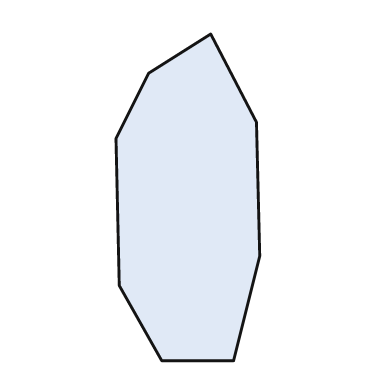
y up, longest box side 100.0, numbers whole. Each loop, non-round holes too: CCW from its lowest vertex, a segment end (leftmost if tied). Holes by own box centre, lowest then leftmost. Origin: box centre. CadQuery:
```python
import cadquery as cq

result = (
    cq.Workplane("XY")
    .moveTo(-8.0, -50.0)
    .lineTo(14.0, -50.0)
    .lineTo(22.0, -18.0)
    .lineTo(21.0, 23.0)
    .lineTo(7.0, 50.0)
    .lineTo(-12.0, 38.0)
    .lineTo(-22.0, 18.0)
    .lineTo(-21.0, -27.0)
    .close()
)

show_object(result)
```